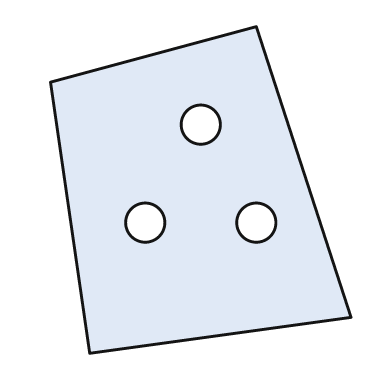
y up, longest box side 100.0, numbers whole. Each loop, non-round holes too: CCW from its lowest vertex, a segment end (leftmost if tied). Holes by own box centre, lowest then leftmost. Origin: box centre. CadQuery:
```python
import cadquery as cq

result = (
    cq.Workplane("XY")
    .moveTo(-34.0, -50.0)
    .lineTo(46.0, -39.0)
    .lineTo(17.0, 50.0)
    .lineTo(-46.0, 33.0)
    .close()
    .moveTo(-17.0, -10.0)
    .circle(6.0)
    .moveTo(17.0, -10.0)
    .circle(6.0)
    .moveTo(0.0, 20.0)
    .circle(6.0)
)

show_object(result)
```